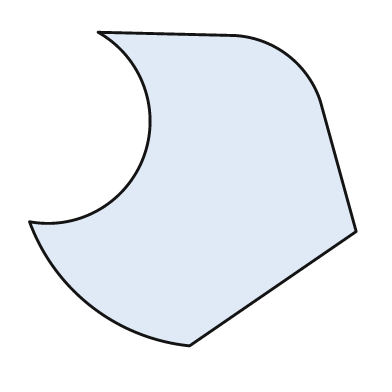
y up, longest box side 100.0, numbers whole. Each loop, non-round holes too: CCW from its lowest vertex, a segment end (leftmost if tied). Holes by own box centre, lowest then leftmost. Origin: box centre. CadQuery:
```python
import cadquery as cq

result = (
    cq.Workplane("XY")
    .moveTo(-1.0, -48.0)
    .lineTo(50.0, -13.0)
    .lineTo(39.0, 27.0)
    .threePointArc((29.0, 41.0), (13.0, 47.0))
    .lineTo(-29.0, 48.0)
    .threePointArc((-15.0, 10.0), (-50.0, -10.0))
    .threePointArc((-31.0, -36.0), (-1.0, -48.0))
    .close()
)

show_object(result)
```